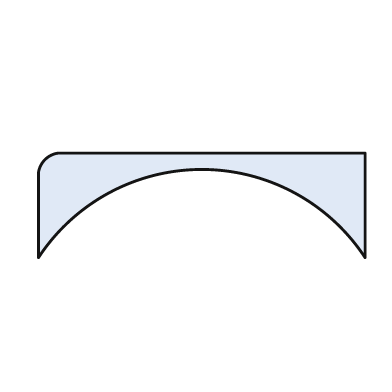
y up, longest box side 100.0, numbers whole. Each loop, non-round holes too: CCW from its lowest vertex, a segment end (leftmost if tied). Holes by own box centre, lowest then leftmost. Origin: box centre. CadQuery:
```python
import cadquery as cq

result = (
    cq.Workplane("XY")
    .moveTo(-50.0, -16.0)
    .threePointArc((0.0, 11.0), (50.0, -16.0))
    .lineTo(50.0, 16.0)
    .lineTo(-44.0, 16.0)
    .threePointArc((-48.0, 14.0), (-50.0, 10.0))
    .close()
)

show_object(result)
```